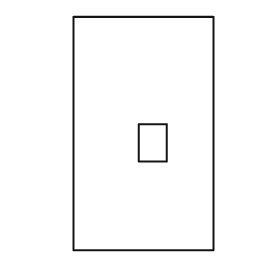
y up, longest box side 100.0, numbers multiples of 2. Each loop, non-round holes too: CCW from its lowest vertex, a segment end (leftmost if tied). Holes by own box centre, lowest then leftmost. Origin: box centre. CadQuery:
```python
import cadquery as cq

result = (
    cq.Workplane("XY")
    .moveTo(-30.0, -50.0)
    .lineTo(30.0, -50.0)
    .lineTo(30.0, 50.0)
    .lineTo(-30.0, 50.0)
    .close()
    .moveTo(-2.0, -12.0)
    .lineTo(10.0, -12.0)
    .lineTo(10.0, 4.0)
    .lineTo(-2.0, 4.0)
    .close()
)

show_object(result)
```